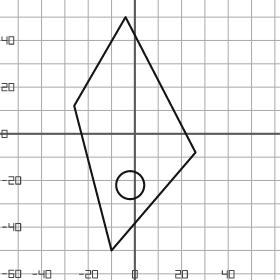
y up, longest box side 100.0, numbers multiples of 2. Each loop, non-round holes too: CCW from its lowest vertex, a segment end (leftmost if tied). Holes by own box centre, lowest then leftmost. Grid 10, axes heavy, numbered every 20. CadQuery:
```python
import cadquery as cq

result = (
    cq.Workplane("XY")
    .moveTo(-10.0, -50.0)
    .lineTo(26.0, -8.0)
    .lineTo(-4.0, 50.0)
    .lineTo(-26.0, 12.0)
    .close()
    .moveTo(-2.0, -22.0)
    .circle(6.0)
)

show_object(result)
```